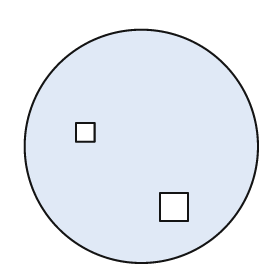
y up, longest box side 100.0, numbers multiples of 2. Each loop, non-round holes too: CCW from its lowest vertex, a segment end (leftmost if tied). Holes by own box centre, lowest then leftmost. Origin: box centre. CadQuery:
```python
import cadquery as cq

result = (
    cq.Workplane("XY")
    .moveTo(0.0, 0.0)
    .circle(50.0)
    .moveTo(8.0, -32.0)
    .lineTo(20.0, -32.0)
    .lineTo(20.0, -20.0)
    .lineTo(8.0, -20.0)
    .close()
    .moveTo(-28.0, 2.0)
    .lineTo(-20.0, 2.0)
    .lineTo(-20.0, 10.0)
    .lineTo(-28.0, 10.0)
    .close()
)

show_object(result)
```